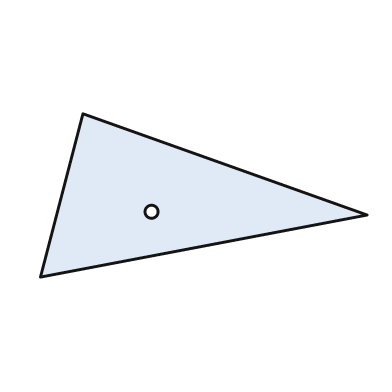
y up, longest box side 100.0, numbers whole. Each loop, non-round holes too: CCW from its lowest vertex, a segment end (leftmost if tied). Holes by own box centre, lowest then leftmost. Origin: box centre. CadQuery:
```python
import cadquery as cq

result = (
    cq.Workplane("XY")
    .moveTo(-50.0, -25.0)
    .lineTo(50.0, -6.0)
    .lineTo(-37.0, 25.0)
    .close()
    .moveTo(-16.0, -5.0)
    .circle(2.0)
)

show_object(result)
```